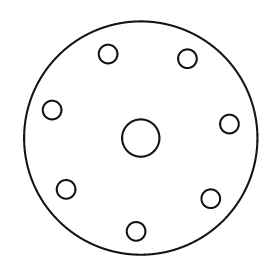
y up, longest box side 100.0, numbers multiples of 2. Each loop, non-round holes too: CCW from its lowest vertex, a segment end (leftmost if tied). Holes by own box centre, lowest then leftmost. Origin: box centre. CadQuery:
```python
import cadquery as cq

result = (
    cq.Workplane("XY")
    .moveTo(0.0, 0.0)
    .circle(50.0)
    .moveTo(-2.0, -40.0)
    .circle(4.0)
    .moveTo(30.0, -26.0)
    .circle(4.0)
    .moveTo(-32.0, -22.0)
    .circle(4.0)
    .moveTo(0.0, 0.0)
    .circle(8.0)
    .moveTo(38.0, 6.0)
    .circle(4.0)
    .moveTo(-38.0, 12.0)
    .circle(4.0)
    .moveTo(20.0, 34.0)
    .circle(4.0)
    .moveTo(-14.0, 36.0)
    .circle(4.0)
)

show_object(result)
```